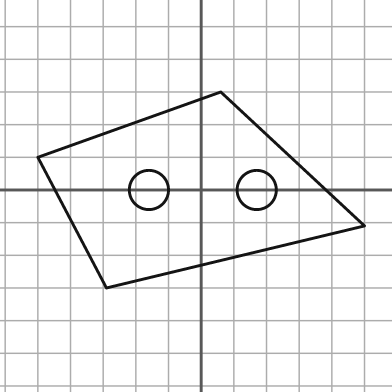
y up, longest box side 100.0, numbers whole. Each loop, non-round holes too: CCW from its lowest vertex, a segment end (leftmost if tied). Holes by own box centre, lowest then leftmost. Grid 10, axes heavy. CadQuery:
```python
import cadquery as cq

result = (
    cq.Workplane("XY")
    .moveTo(-29.0, -30.0)
    .lineTo(50.0, -11.0)
    .lineTo(6.0, 30.0)
    .lineTo(-50.0, 10.0)
    .close()
    .moveTo(-16.0, 0.0)
    .circle(6.0)
    .moveTo(17.0, 0.0)
    .circle(6.0)
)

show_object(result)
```